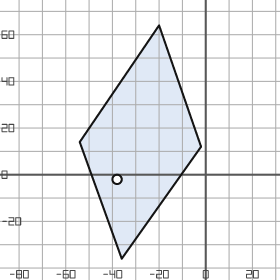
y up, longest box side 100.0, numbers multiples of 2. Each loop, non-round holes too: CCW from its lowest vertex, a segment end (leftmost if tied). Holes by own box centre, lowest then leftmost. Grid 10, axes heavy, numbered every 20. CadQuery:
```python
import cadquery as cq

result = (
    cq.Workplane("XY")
    .moveTo(-36.0, -36.0)
    .lineTo(-2.0, 12.0)
    .lineTo(-20.0, 64.0)
    .lineTo(-54.0, 14.0)
    .close()
    .moveTo(-38.0, -2.0)
    .circle(2.0)
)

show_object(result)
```